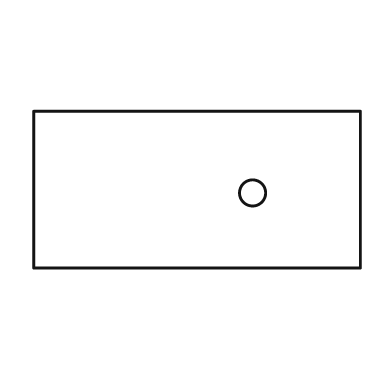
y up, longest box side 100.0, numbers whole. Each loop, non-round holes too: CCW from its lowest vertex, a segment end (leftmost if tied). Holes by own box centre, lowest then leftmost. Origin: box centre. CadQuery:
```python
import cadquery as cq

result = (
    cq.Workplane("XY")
    .moveTo(-50.0, -24.0)
    .lineTo(50.0, -24.0)
    .lineTo(50.0, 24.0)
    .lineTo(-50.0, 24.0)
    .close()
    .moveTo(17.0, -1.0)
    .circle(4.0)
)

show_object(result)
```